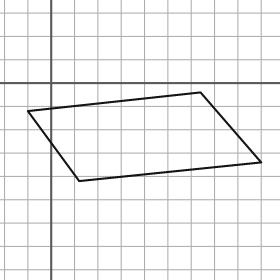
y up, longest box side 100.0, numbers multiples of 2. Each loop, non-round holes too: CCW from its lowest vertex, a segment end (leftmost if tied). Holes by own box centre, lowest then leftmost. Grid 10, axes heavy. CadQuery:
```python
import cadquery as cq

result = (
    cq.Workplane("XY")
    .moveTo(12.0, -42.0)
    .lineTo(90.0, -34.0)
    .lineTo(64.0, -4.0)
    .lineTo(-10.0, -12.0)
    .close()
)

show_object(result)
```